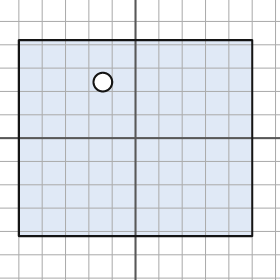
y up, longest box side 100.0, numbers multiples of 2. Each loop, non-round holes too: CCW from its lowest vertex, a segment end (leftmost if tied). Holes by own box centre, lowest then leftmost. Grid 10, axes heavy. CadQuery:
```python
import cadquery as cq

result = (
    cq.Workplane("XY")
    .moveTo(-50.0, -42.0)
    .lineTo(50.0, -42.0)
    .lineTo(50.0, 42.0)
    .lineTo(-50.0, 42.0)
    .close()
    .moveTo(-14.0, 24.0)
    .circle(4.0)
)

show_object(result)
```